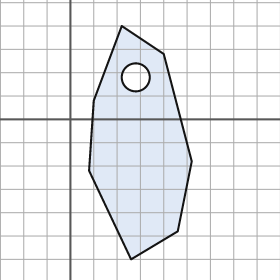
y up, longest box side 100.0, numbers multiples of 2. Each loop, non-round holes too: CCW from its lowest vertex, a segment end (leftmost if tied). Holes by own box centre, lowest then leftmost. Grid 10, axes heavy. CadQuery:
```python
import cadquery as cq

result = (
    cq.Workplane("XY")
    .moveTo(26.0, -60.0)
    .lineTo(46.0, -48.0)
    .lineTo(52.0, -18.0)
    .lineTo(40.0, 28.0)
    .lineTo(22.0, 40.0)
    .lineTo(10.0, 8.0)
    .lineTo(8.0, -22.0)
    .close()
    .moveTo(28.0, 18.0)
    .circle(6.0)
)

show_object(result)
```